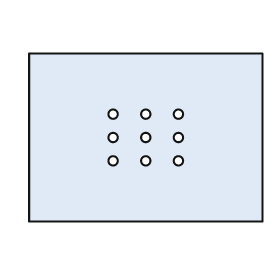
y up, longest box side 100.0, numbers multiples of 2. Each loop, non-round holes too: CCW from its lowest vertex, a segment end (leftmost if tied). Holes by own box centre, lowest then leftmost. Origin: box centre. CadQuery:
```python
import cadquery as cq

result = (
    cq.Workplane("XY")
    .moveTo(-50.0, -36.0)
    .lineTo(50.0, -36.0)
    .lineTo(50.0, 36.0)
    .lineTo(-50.0, 36.0)
    .close()
    .moveTo(-14.0, -10.0)
    .circle(2.0)
    .moveTo(0.0, -10.0)
    .circle(2.0)
    .moveTo(14.0, -10.0)
    .circle(2.0)
    .moveTo(-14.0, 0.0)
    .circle(2.0)
    .moveTo(0.0, 0.0)
    .circle(2.0)
    .moveTo(14.0, 0.0)
    .circle(2.0)
    .moveTo(-14.0, 10.0)
    .circle(2.0)
    .moveTo(0.0, 10.0)
    .circle(2.0)
    .moveTo(14.0, 10.0)
    .circle(2.0)
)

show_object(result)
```